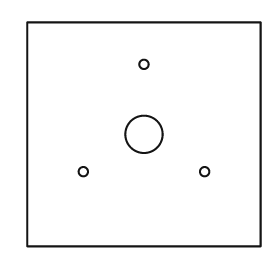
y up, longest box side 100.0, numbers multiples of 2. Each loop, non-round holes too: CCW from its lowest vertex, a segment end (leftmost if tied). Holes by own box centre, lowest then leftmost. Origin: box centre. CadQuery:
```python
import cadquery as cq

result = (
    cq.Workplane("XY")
    .moveTo(-50.0, -48.0)
    .lineTo(50.0, -48.0)
    .lineTo(50.0, 48.0)
    .lineTo(-50.0, 48.0)
    .close()
    .moveTo(-26.0, -16.0)
    .circle(2.0)
    .moveTo(26.0, -16.0)
    .circle(2.0)
    .moveTo(0.0, 0.0)
    .circle(8.0)
    .moveTo(0.0, 30.0)
    .circle(2.0)
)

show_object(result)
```